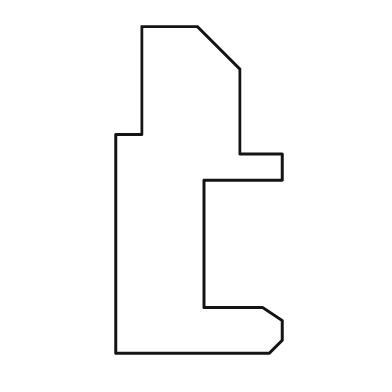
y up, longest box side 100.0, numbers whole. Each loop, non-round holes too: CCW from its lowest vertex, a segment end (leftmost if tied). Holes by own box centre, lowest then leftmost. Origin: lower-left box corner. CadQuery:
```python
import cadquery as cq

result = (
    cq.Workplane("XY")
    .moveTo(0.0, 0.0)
    .lineTo(47.0, 0.0)
    .lineTo(51.0, 4.0)
    .lineTo(51.0, 10.0)
    .lineTo(45.0, 14.0)
    .lineTo(27.0, 14.0)
    .lineTo(27.0, 53.0)
    .lineTo(51.0, 53.0)
    .lineTo(51.0, 61.0)
    .lineTo(38.0, 61.0)
    .lineTo(38.0, 87.0)
    .lineTo(25.0, 100.0)
    .lineTo(8.0, 100.0)
    .lineTo(8.0, 67.0)
    .lineTo(0.0, 67.0)
    .close()
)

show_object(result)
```